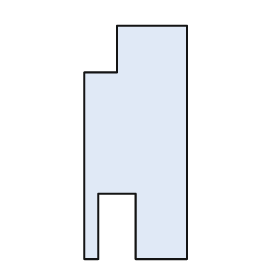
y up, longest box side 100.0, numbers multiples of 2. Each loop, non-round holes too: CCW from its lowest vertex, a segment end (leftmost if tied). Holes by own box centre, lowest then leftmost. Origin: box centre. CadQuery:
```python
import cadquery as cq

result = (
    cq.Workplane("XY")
    .moveTo(-22.0, -50.0)
    .lineTo(-16.0, -50.0)
    .lineTo(-16.0, -22.0)
    .lineTo(0.0, -22.0)
    .lineTo(0.0, -50.0)
    .lineTo(22.0, -50.0)
    .lineTo(22.0, 50.0)
    .lineTo(-8.0, 50.0)
    .lineTo(-8.0, 30.0)
    .lineTo(-22.0, 30.0)
    .close()
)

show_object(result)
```